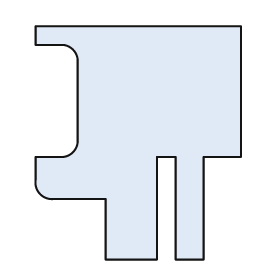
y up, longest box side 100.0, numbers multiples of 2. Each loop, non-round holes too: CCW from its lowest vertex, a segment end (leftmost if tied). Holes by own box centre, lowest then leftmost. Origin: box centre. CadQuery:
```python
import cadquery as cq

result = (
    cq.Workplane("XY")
    .moveTo(-14.0, -50.0)
    .lineTo(8.0, -50.0)
    .lineTo(8.0, -6.0)
    .lineTo(16.0, -6.0)
    .lineTo(16.0, -50.0)
    .lineTo(28.0, -50.0)
    .lineTo(28.0, -6.0)
    .lineTo(44.0, -6.0)
    .lineTo(44.0, 50.0)
    .lineTo(-44.0, 50.0)
    .lineTo(-44.0, 42.0)
    .lineTo(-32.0, 42.0)
    .threePointArc((-28.0, 40.0), (-26.0, 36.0))
    .lineTo(-26.0, 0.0)
    .threePointArc((-28.0, -4.0), (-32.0, -6.0))
    .lineTo(-44.0, -6.0)
    .lineTo(-44.0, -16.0)
    .threePointArc((-42.0, -22.0), (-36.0, -24.0))
    .lineTo(-14.0, -24.0)
    .close()
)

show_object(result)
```